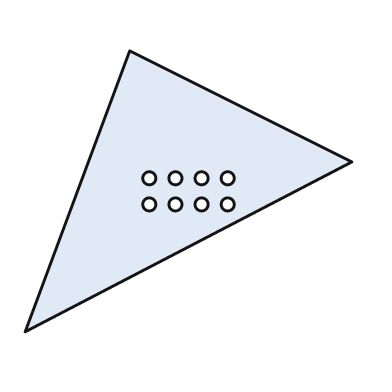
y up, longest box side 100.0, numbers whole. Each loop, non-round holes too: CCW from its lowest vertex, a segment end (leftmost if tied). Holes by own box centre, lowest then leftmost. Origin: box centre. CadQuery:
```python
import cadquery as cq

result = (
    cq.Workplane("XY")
    .moveTo(-50.0, -43.0)
    .lineTo(50.0, 9.0)
    .lineTo(-18.0, 43.0)
    .close()
    .moveTo(-12.0, -4.0)
    .circle(2.0)
    .moveTo(-4.0, -4.0)
    .circle(2.0)
    .moveTo(4.0, -4.0)
    .circle(2.0)
    .moveTo(12.0, -4.0)
    .circle(2.0)
    .moveTo(-12.0, 4.0)
    .circle(2.0)
    .moveTo(-4.0, 4.0)
    .circle(2.0)
    .moveTo(4.0, 4.0)
    .circle(2.0)
    .moveTo(12.0, 4.0)
    .circle(2.0)
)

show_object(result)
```